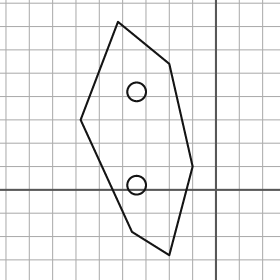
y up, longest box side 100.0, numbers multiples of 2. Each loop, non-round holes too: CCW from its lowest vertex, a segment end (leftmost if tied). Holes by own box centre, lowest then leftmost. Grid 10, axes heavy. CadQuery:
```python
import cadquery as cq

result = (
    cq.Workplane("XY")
    .moveTo(-20.0, -28.0)
    .lineTo(-10.0, 10.0)
    .lineTo(-20.0, 54.0)
    .lineTo(-42.0, 72.0)
    .lineTo(-58.0, 30.0)
    .lineTo(-36.0, -18.0)
    .close()
    .moveTo(-34.0, 2.0)
    .circle(4.0)
    .moveTo(-34.0, 42.0)
    .circle(4.0)
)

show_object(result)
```